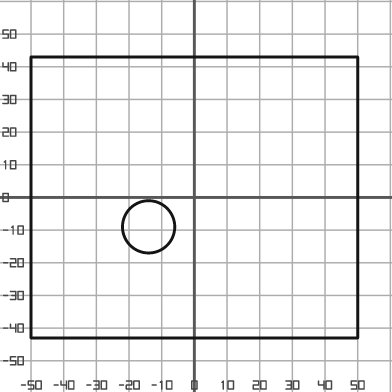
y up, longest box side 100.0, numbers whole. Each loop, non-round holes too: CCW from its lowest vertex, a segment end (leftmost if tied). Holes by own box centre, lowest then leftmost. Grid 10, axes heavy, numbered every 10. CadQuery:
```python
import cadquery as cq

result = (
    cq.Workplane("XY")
    .moveTo(-50.0, -43.0)
    .lineTo(50.0, -43.0)
    .lineTo(50.0, 43.0)
    .lineTo(-50.0, 43.0)
    .close()
    .moveTo(-14.0, -9.0)
    .circle(8.0)
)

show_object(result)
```